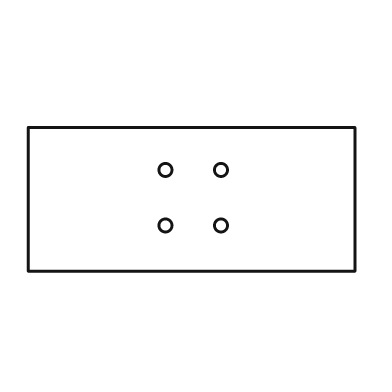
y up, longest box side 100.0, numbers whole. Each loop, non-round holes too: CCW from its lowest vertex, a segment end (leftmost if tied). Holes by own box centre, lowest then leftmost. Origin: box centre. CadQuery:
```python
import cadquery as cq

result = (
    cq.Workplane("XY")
    .moveTo(-50.0, -22.0)
    .lineTo(50.0, -22.0)
    .lineTo(50.0, 22.0)
    .lineTo(-50.0, 22.0)
    .close()
    .moveTo(-8.0, -8.0)
    .circle(2.0)
    .moveTo(9.0, -8.0)
    .circle(2.0)
    .moveTo(-8.0, 9.0)
    .circle(2.0)
    .moveTo(9.0, 9.0)
    .circle(2.0)
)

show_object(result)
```